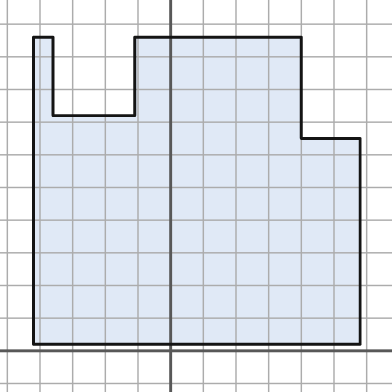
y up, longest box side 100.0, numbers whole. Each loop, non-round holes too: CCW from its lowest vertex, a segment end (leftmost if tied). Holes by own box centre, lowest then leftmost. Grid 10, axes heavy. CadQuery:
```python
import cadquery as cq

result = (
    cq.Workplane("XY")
    .moveTo(-42.0, 2.0)
    .lineTo(58.0, 2.0)
    .lineTo(58.0, 65.0)
    .lineTo(40.0, 65.0)
    .lineTo(40.0, 96.0)
    .lineTo(-11.0, 96.0)
    .lineTo(-11.0, 72.0)
    .lineTo(-36.0, 72.0)
    .lineTo(-36.0, 96.0)
    .lineTo(-42.0, 96.0)
    .close()
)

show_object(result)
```